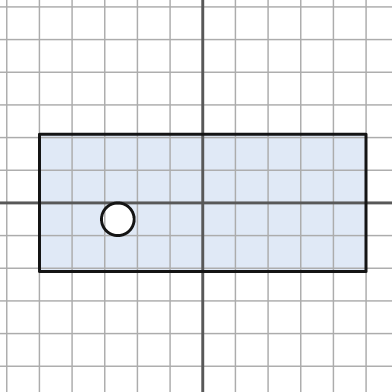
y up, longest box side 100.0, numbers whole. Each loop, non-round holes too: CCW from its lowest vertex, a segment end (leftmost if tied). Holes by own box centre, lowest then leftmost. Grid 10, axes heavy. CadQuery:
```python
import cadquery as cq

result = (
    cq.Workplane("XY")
    .moveTo(-50.0, -21.0)
    .lineTo(50.0, -21.0)
    .lineTo(50.0, 21.0)
    .lineTo(-50.0, 21.0)
    .close()
    .moveTo(-26.0, -5.0)
    .circle(5.0)
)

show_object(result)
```